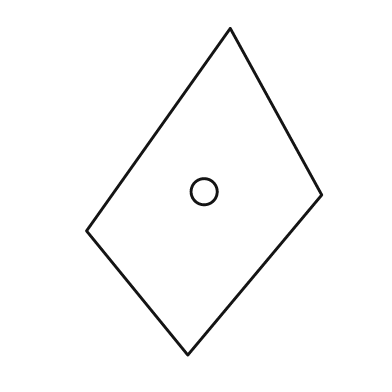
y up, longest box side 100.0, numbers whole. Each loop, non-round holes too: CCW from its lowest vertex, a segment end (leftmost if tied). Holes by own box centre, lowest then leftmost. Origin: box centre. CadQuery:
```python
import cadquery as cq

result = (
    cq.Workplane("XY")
    .moveTo(-5.0, -50.0)
    .lineTo(36.0, -1.0)
    .lineTo(8.0, 50.0)
    .lineTo(-36.0, -12.0)
    .close()
    .moveTo(0.0, 0.0)
    .circle(4.0)
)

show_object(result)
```